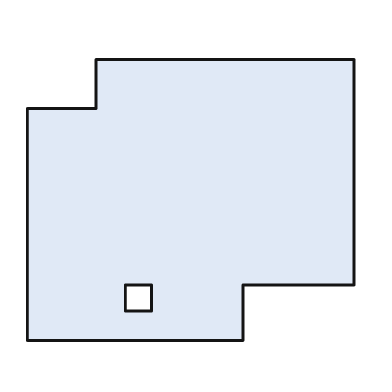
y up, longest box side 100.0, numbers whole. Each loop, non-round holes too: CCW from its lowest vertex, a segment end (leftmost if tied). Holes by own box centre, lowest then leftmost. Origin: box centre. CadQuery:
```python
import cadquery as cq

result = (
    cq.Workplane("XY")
    .moveTo(-50.0, -43.0)
    .lineTo(16.0, -43.0)
    .lineTo(16.0, -26.0)
    .lineTo(50.0, -26.0)
    .lineTo(50.0, 43.0)
    .lineTo(-29.0, 43.0)
    .lineTo(-29.0, 28.0)
    .lineTo(-50.0, 28.0)
    .close()
    .moveTo(-20.0, -34.0)
    .lineTo(-12.0, -34.0)
    .lineTo(-12.0, -26.0)
    .lineTo(-20.0, -26.0)
    .close()
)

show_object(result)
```